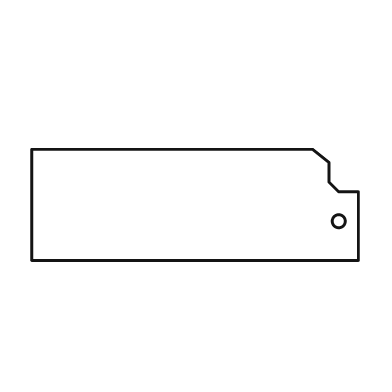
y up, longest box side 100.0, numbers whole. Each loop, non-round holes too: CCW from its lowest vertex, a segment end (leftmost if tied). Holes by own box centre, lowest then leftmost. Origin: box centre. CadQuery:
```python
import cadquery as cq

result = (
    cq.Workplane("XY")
    .moveTo(-50.0, -17.0)
    .lineTo(50.0, -17.0)
    .lineTo(50.0, 4.0)
    .lineTo(44.0, 4.0)
    .lineTo(41.0, 7.0)
    .lineTo(41.0, 13.0)
    .lineTo(36.0, 17.0)
    .lineTo(-50.0, 17.0)
    .close()
    .moveTo(44.0, -5.0)
    .circle(2.0)
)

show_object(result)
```